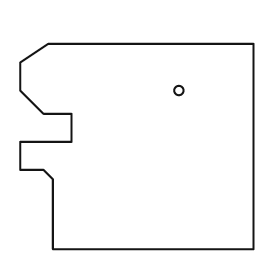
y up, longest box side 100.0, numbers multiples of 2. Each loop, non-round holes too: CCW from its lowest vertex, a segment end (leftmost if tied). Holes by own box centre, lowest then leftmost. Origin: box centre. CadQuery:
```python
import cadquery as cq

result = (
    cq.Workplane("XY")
    .moveTo(-36.0, -44.0)
    .lineTo(50.0, -44.0)
    .lineTo(50.0, 44.0)
    .lineTo(-38.0, 44.0)
    .lineTo(-50.0, 36.0)
    .lineTo(-50.0, 24.0)
    .lineTo(-40.0, 14.0)
    .lineTo(-28.0, 14.0)
    .lineTo(-28.0, 2.0)
    .lineTo(-50.0, 2.0)
    .lineTo(-50.0, -10.0)
    .lineTo(-40.0, -10.0)
    .lineTo(-36.0, -14.0)
    .close()
    .moveTo(18.0, 24.0)
    .circle(2.0)
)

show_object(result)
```